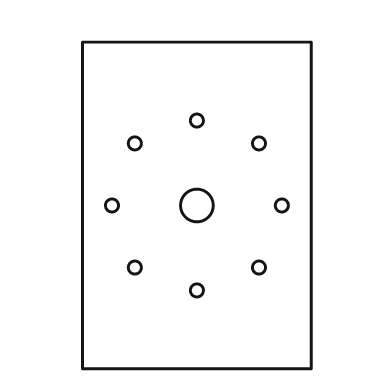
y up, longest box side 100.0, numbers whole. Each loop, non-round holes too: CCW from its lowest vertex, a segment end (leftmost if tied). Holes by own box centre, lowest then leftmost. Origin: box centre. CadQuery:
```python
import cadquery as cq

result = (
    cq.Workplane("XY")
    .moveTo(-35.0, -50.0)
    .lineTo(35.0, -50.0)
    .lineTo(35.0, 50.0)
    .lineTo(-35.0, 50.0)
    .close()
    .moveTo(0.0, -26.0)
    .circle(2.0)
    .moveTo(-19.0, -19.0)
    .circle(2.0)
    .moveTo(19.0, -19.0)
    .circle(2.0)
    .moveTo(-26.0, 0.0)
    .circle(2.0)
    .moveTo(0.0, 0.0)
    .circle(5.0)
    .moveTo(26.0, 0.0)
    .circle(2.0)
    .moveTo(-19.0, 19.0)
    .circle(2.0)
    .moveTo(19.0, 19.0)
    .circle(2.0)
    .moveTo(0.0, 26.0)
    .circle(2.0)
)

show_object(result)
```